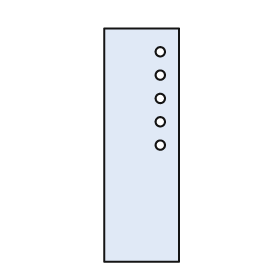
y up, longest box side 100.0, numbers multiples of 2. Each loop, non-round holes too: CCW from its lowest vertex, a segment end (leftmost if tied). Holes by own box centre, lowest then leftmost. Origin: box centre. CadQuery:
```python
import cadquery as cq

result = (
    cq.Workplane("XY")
    .moveTo(-16.0, -50.0)
    .lineTo(16.0, -50.0)
    .lineTo(16.0, 50.0)
    .lineTo(-16.0, 50.0)
    .close()
    .moveTo(8.0, 0.0)
    .circle(2.0)
    .moveTo(8.0, 10.0)
    .circle(2.0)
    .moveTo(8.0, 20.0)
    .circle(2.0)
    .moveTo(8.0, 30.0)
    .circle(2.0)
    .moveTo(8.0, 40.0)
    .circle(2.0)
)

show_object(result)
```